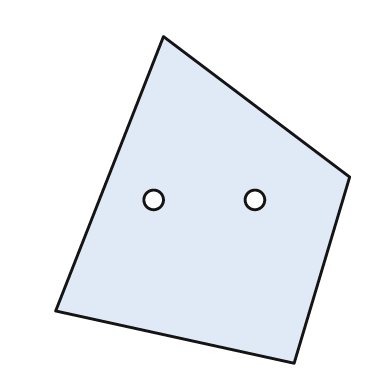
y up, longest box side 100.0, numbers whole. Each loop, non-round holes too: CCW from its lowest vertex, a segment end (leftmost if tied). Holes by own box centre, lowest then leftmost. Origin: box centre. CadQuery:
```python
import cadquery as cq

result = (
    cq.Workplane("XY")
    .moveTo(28.0, -50.0)
    .lineTo(45.0, 7.0)
    .lineTo(-12.0, 50.0)
    .lineTo(-45.0, -34.0)
    .close()
    .moveTo(-15.0, 0.0)
    .circle(3.0)
    .moveTo(16.0, 0.0)
    .circle(3.0)
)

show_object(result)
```